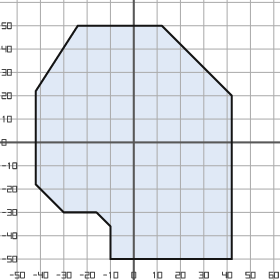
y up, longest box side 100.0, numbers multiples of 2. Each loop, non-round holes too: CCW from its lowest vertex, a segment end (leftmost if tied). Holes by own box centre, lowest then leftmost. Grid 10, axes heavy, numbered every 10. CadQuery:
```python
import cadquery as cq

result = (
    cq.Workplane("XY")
    .moveTo(-10.0, -50.0)
    .lineTo(42.0, -50.0)
    .lineTo(42.0, 20.0)
    .lineTo(12.0, 50.0)
    .lineTo(-24.0, 50.0)
    .lineTo(-42.0, 22.0)
    .lineTo(-42.0, -18.0)
    .lineTo(-30.0, -30.0)
    .lineTo(-16.0, -30.0)
    .lineTo(-10.0, -36.0)
    .close()
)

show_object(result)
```